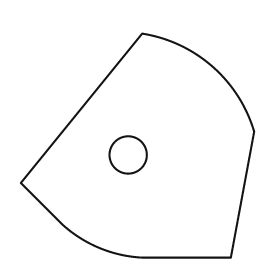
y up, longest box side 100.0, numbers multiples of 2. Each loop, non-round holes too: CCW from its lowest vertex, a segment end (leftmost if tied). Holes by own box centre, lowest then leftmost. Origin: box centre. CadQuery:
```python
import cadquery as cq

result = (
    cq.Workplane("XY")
    .moveTo(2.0, -48.0)
    .lineTo(40.0, -48.0)
    .lineTo(50.0, 6.0)
    .threePointArc((32.0, 34.0), (2.0, 48.0))
    .lineTo(-50.0, -16.0)
    .lineTo(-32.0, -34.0)
    .threePointArc((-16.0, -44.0), (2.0, -48.0))
    .close()
    .moveTo(-4.0, -4.0)
    .circle(8.0)
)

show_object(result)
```